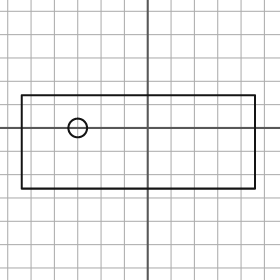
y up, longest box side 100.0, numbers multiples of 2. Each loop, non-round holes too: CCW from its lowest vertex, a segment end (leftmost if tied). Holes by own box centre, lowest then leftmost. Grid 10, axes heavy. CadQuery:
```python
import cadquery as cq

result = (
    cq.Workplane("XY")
    .moveTo(-54.0, -26.0)
    .lineTo(46.0, -26.0)
    .lineTo(46.0, 14.0)
    .lineTo(-54.0, 14.0)
    .close()
    .moveTo(-30.0, 0.0)
    .circle(4.0)
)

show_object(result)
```